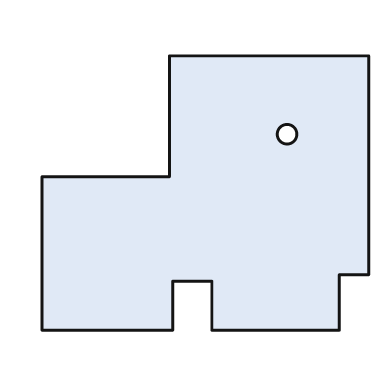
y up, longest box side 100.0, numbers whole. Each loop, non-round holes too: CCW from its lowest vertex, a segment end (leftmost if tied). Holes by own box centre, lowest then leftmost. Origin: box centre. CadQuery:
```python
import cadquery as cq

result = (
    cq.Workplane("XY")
    .moveTo(-50.0, -42.0)
    .lineTo(-10.0, -42.0)
    .lineTo(-10.0, -27.0)
    .lineTo(2.0, -27.0)
    .lineTo(2.0, -42.0)
    .lineTo(41.0, -42.0)
    .lineTo(41.0, -25.0)
    .lineTo(50.0, -25.0)
    .lineTo(50.0, 42.0)
    .lineTo(-11.0, 42.0)
    .lineTo(-11.0, 5.0)
    .lineTo(-50.0, 5.0)
    .close()
    .moveTo(25.0, 18.0)
    .circle(3.0)
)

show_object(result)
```